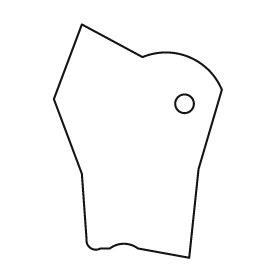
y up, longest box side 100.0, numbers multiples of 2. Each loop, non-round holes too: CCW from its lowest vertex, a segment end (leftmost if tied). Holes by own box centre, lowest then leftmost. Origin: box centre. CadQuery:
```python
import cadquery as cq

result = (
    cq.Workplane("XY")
    .moveTo(22.0, -50.0)
    .lineTo(26.0, -12.0)
    .lineTo(36.0, 22.0)
    .threePointArc((22.0, 36.0), (2.0, 36.0))
    .lineTo(-24.0, 50.0)
    .lineTo(-36.0, 18.0)
    .lineTo(-24.0, -14.0)
    .lineTo(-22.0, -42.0)
    .threePointArc((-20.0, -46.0), (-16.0, -46.0))
    .lineTo(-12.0, -46.0)
    .threePointArc((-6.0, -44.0), (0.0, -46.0))
    .close()
    .moveTo(20.0, 16.0)
    .circle(4.0)
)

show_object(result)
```